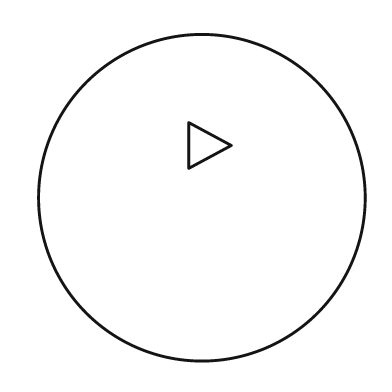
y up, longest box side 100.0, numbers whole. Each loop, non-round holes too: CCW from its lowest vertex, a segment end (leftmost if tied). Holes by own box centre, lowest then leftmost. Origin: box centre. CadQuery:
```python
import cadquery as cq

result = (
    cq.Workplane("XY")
    .moveTo(0.0, 0.0)
    .circle(50.0)
    .moveTo(-4.0, 9.0)
    .lineTo(9.0, 16.0)
    .lineTo(-4.0, 23.0)
    .close()
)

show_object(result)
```